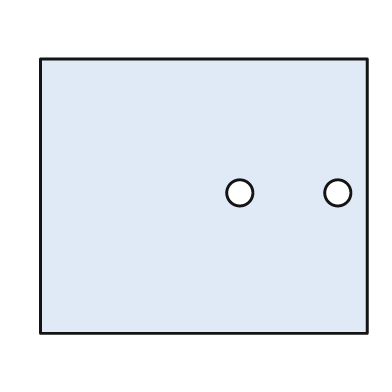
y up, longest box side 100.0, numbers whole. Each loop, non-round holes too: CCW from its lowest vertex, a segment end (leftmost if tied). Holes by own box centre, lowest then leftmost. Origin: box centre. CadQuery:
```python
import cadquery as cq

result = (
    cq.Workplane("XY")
    .moveTo(-50.0, -42.0)
    .lineTo(50.0, -42.0)
    .lineTo(50.0, 42.0)
    .lineTo(-50.0, 42.0)
    .close()
    .moveTo(11.0, 1.0)
    .circle(4.0)
    .moveTo(41.0, 1.0)
    .circle(4.0)
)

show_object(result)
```